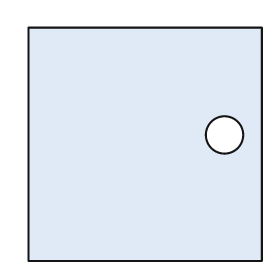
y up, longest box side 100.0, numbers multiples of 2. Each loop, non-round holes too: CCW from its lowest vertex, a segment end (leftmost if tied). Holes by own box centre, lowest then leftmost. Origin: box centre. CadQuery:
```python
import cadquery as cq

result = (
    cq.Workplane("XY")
    .moveTo(-50.0, -50.0)
    .lineTo(50.0, -50.0)
    .lineTo(50.0, 50.0)
    .lineTo(-50.0, 50.0)
    .close()
    .moveTo(34.0, 4.0)
    .circle(8.0)
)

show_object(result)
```